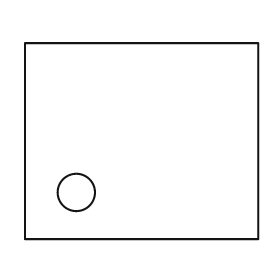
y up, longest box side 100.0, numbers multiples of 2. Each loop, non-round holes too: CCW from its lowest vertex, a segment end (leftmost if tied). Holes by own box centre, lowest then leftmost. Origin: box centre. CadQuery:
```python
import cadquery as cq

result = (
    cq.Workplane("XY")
    .moveTo(-50.0, -42.0)
    .lineTo(50.0, -42.0)
    .lineTo(50.0, 42.0)
    .lineTo(-50.0, 42.0)
    .close()
    .moveTo(-28.0, -22.0)
    .circle(8.0)
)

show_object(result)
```